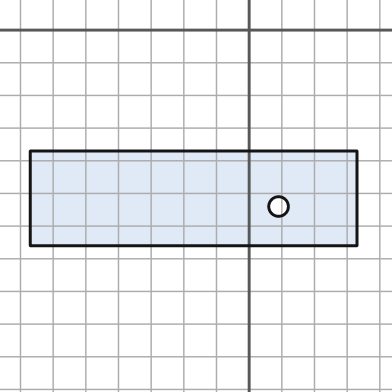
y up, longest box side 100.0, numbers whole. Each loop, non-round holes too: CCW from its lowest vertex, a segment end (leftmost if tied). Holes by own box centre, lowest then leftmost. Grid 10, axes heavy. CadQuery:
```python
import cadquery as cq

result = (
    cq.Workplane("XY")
    .moveTo(-67.0, -66.0)
    .lineTo(33.0, -66.0)
    .lineTo(33.0, -37.0)
    .lineTo(-67.0, -37.0)
    .close()
    .moveTo(9.0, -54.0)
    .circle(3.0)
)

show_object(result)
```